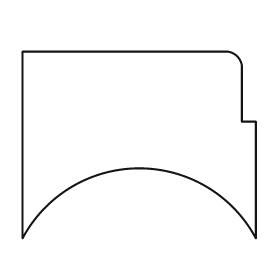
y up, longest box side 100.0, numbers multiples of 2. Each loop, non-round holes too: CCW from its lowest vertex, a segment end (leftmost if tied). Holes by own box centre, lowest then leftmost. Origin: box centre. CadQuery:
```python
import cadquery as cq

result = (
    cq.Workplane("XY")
    .moveTo(-50.0, -40.0)
    .threePointArc((0.0, -10.0), (50.0, -40.0))
    .lineTo(50.0, 10.0)
    .lineTo(44.0, 10.0)
    .lineTo(44.0, 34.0)
    .threePointArc((42.0, 38.0), (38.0, 40.0))
    .lineTo(-50.0, 40.0)
    .close()
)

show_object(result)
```